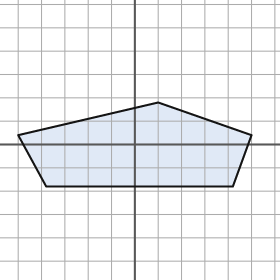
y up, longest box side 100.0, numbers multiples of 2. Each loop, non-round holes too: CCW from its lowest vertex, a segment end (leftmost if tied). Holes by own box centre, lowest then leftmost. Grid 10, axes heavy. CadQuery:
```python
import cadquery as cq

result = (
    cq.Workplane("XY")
    .moveTo(-38.0, -18.0)
    .lineTo(42.0, -18.0)
    .lineTo(50.0, 4.0)
    .lineTo(10.0, 18.0)
    .lineTo(-50.0, 4.0)
    .close()
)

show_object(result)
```